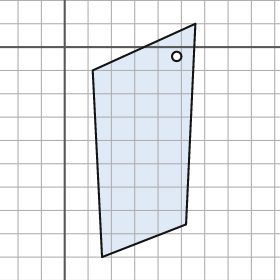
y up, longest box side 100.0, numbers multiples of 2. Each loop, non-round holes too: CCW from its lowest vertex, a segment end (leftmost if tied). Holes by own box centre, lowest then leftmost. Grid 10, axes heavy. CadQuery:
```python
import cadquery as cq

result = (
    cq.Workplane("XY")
    .moveTo(16.0, -90.0)
    .lineTo(52.0, -76.0)
    .lineTo(56.0, 10.0)
    .lineTo(12.0, -10.0)
    .close()
    .moveTo(48.0, -4.0)
    .circle(2.0)
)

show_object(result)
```